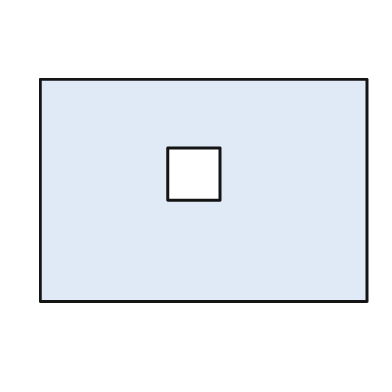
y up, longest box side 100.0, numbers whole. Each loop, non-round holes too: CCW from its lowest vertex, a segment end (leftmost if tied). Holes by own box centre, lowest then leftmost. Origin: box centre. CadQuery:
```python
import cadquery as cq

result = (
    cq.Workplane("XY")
    .moveTo(-50.0, -34.0)
    .lineTo(50.0, -34.0)
    .lineTo(50.0, 34.0)
    .lineTo(-50.0, 34.0)
    .close()
    .moveTo(-11.0, -3.0)
    .lineTo(5.0, -3.0)
    .lineTo(5.0, 13.0)
    .lineTo(-11.0, 13.0)
    .close()
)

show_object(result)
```